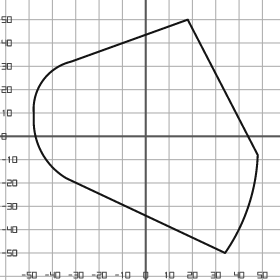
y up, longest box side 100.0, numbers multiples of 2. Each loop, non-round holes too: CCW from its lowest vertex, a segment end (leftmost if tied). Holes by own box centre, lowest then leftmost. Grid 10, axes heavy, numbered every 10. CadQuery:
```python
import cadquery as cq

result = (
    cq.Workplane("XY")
    .moveTo(34.0, -50.0)
    .threePointArc((44.0, -30.0), (48.0, -8.0))
    .lineTo(18.0, 50.0)
    .lineTo(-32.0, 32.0)
    .threePointArc((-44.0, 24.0), (-48.0, 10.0))
    .lineTo(-48.0, 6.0)
    .threePointArc((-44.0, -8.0), (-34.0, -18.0))
    .close()
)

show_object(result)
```